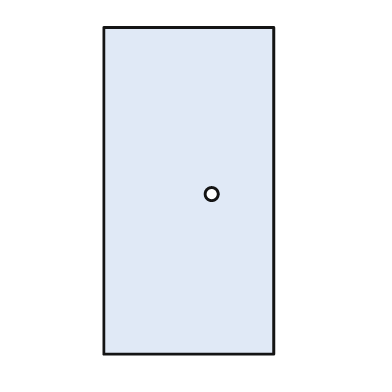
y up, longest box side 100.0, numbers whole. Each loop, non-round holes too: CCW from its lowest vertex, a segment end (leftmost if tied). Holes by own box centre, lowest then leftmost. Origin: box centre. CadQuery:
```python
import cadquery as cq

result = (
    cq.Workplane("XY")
    .moveTo(-26.0, -50.0)
    .lineTo(26.0, -50.0)
    .lineTo(26.0, 50.0)
    .lineTo(-26.0, 50.0)
    .close()
    .moveTo(7.0, -1.0)
    .circle(2.0)
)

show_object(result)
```